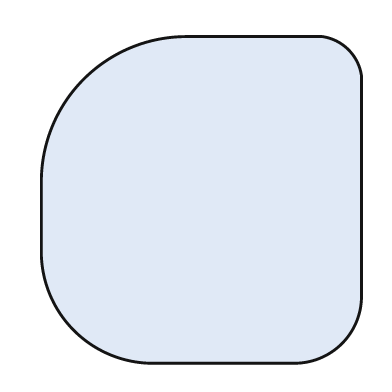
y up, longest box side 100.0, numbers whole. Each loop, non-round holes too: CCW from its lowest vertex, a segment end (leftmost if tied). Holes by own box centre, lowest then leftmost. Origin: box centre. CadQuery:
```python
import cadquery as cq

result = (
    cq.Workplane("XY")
    .moveTo(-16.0, -50.0)
    .lineTo(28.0, -50.0)
    .threePointArc((43.0, -44.0), (49.0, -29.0))
    .lineTo(49.0, 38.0)
    .threePointArc((45.0, 46.0), (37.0, 50.0))
    .lineTo(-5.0, 50.0)
    .threePointArc((-36.0, 37.0), (-49.0, 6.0))
    .lineTo(-49.0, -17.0)
    .threePointArc((-39.0, -40.0), (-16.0, -50.0))
    .close()
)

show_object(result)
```